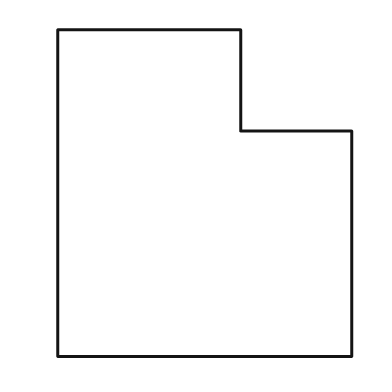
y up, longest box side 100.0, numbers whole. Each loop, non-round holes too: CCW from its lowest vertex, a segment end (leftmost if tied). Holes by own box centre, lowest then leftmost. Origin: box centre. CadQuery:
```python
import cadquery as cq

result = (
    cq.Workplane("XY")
    .moveTo(-45.0, -50.0)
    .lineTo(45.0, -50.0)
    .lineTo(45.0, 19.0)
    .lineTo(11.0, 19.0)
    .lineTo(11.0, 50.0)
    .lineTo(-45.0, 50.0)
    .close()
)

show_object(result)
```